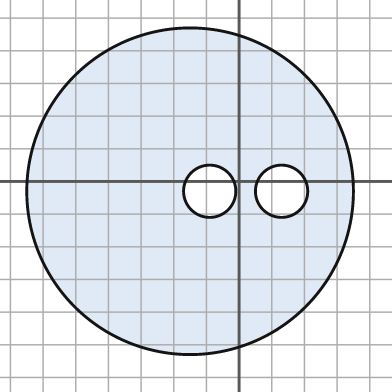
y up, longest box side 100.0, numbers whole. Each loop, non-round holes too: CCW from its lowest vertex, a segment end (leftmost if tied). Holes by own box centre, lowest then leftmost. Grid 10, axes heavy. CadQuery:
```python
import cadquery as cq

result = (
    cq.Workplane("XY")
    .moveTo(-15.0, -3.0)
    .circle(50.0)
    .moveTo(-9.0, -3.0)
    .circle(8.0)
    .moveTo(13.0, -3.0)
    .circle(8.0)
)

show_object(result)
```